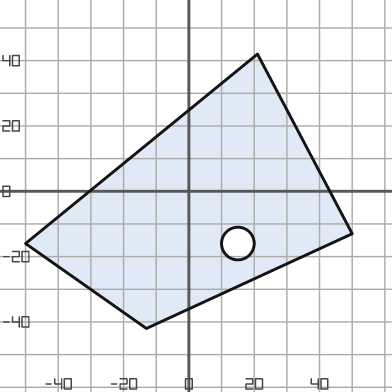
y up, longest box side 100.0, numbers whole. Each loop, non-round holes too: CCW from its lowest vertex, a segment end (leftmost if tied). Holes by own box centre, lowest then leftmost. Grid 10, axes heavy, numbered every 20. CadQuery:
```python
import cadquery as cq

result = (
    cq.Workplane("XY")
    .moveTo(-13.0, -42.0)
    .lineTo(50.0, -13.0)
    .lineTo(21.0, 42.0)
    .lineTo(-50.0, -16.0)
    .close()
    .moveTo(15.0, -16.0)
    .circle(5.0)
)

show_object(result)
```